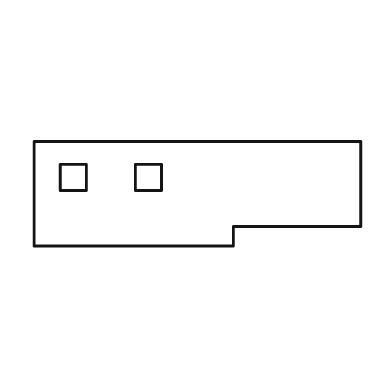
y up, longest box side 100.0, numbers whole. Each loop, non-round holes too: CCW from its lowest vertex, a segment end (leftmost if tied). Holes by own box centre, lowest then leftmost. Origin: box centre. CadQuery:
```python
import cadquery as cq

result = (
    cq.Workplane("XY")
    .moveTo(-50.0, -16.0)
    .lineTo(11.0, -16.0)
    .lineTo(11.0, -10.0)
    .lineTo(50.0, -10.0)
    .lineTo(50.0, 16.0)
    .lineTo(-50.0, 16.0)
    .close()
    .moveTo(-42.0, 1.0)
    .lineTo(-34.0, 1.0)
    .lineTo(-34.0, 9.0)
    .lineTo(-42.0, 9.0)
    .close()
    .moveTo(-19.0, 1.0)
    .lineTo(-11.0, 1.0)
    .lineTo(-11.0, 9.0)
    .lineTo(-19.0, 9.0)
    .close()
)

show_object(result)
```